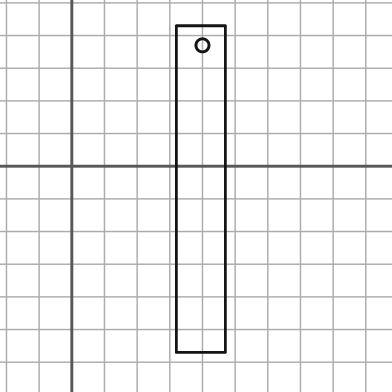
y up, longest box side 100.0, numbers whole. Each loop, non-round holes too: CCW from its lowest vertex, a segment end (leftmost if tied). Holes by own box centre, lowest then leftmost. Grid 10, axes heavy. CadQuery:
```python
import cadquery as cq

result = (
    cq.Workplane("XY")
    .moveTo(32.0, -57.0)
    .lineTo(47.0, -57.0)
    .lineTo(47.0, 43.0)
    .lineTo(32.0, 43.0)
    .close()
    .moveTo(40.0, 37.0)
    .circle(2.0)
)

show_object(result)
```